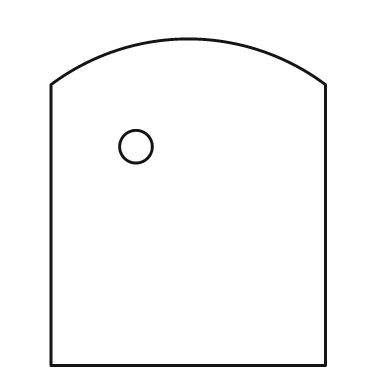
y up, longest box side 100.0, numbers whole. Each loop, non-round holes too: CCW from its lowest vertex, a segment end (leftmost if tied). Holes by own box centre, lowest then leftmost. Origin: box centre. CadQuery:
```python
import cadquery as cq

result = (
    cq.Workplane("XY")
    .moveTo(-42.0, -50.0)
    .lineTo(42.0, -50.0)
    .lineTo(42.0, 36.0)
    .threePointArc((0.0, 50.0), (-42.0, 36.0))
    .close()
    .moveTo(-16.0, 17.0)
    .circle(5.0)
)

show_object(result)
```